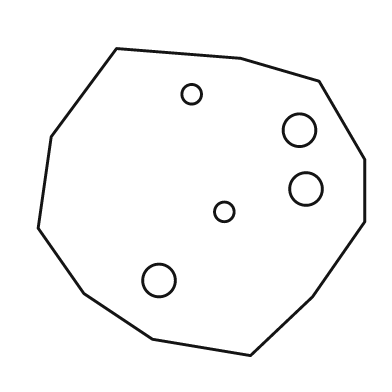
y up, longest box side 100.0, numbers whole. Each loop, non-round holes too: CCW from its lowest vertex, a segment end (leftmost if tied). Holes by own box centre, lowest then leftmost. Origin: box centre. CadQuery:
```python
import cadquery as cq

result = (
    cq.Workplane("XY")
    .moveTo(15.0, -47.0)
    .lineTo(34.0, -29.0)
    .lineTo(50.0, -6.0)
    .lineTo(50.0, 13.0)
    .lineTo(36.0, 37.0)
    .lineTo(12.0, 44.0)
    .lineTo(-26.0, 47.0)
    .lineTo(-46.0, 20.0)
    .lineTo(-50.0, -8.0)
    .lineTo(-36.0, -28.0)
    .lineTo(-15.0, -42.0)
    .close()
    .moveTo(-13.0, -24.0)
    .circle(5.0)
    .moveTo(7.0, -3.0)
    .circle(3.0)
    .moveTo(32.0, 4.0)
    .circle(5.0)
    .moveTo(30.0, 22.0)
    .circle(5.0)
    .moveTo(-3.0, 33.0)
    .circle(3.0)
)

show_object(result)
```